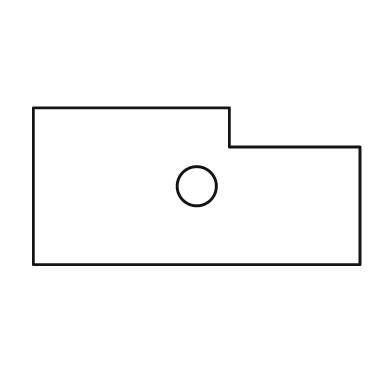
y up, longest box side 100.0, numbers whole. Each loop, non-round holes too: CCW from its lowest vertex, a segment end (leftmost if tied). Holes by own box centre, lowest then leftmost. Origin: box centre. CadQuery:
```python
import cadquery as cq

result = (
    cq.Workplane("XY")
    .moveTo(-50.0, -24.0)
    .lineTo(50.0, -24.0)
    .lineTo(50.0, 12.0)
    .lineTo(10.0, 12.0)
    .lineTo(10.0, 24.0)
    .lineTo(-50.0, 24.0)
    .close()
    .moveTo(0.0, 0.0)
    .circle(6.0)
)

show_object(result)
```